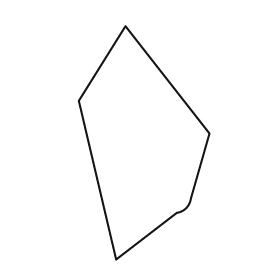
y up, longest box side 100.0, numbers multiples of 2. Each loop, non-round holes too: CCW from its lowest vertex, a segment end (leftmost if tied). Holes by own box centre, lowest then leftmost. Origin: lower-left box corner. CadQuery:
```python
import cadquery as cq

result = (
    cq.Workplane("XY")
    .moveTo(16.0, 0.0)
    .lineTo(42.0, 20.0)
    .threePointArc((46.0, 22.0), (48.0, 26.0))
    .lineTo(56.0, 54.0)
    .lineTo(20.0, 100.0)
    .lineTo(0.0, 68.0)
    .close()
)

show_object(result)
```